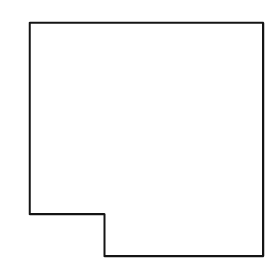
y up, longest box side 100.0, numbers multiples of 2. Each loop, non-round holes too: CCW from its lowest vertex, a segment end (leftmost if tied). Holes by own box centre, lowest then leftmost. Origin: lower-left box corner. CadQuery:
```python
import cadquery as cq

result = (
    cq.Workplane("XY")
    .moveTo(32.0, 0.0)
    .lineTo(100.0, 0.0)
    .lineTo(100.0, 100.0)
    .lineTo(0.0, 100.0)
    .lineTo(0.0, 18.0)
    .lineTo(32.0, 18.0)
    .close()
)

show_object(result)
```